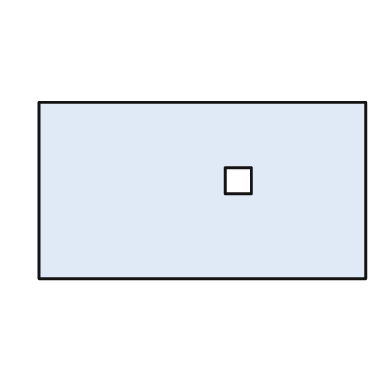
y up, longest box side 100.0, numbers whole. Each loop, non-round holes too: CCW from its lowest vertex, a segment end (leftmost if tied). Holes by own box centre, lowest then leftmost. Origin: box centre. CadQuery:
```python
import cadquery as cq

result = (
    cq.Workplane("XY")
    .moveTo(-50.0, -27.0)
    .lineTo(50.0, -27.0)
    .lineTo(50.0, 27.0)
    .lineTo(-50.0, 27.0)
    .close()
    .moveTo(7.0, -1.0)
    .lineTo(15.0, -1.0)
    .lineTo(15.0, 7.0)
    .lineTo(7.0, 7.0)
    .close()
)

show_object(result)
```